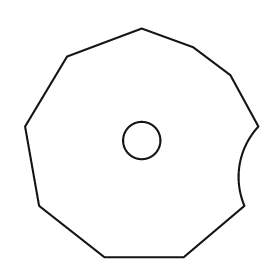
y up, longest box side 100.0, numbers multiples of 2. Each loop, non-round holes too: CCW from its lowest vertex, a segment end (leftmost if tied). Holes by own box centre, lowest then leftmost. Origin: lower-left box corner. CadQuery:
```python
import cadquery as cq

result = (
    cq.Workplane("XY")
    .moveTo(34.0, 0.0)
    .lineTo(68.0, 0.0)
    .lineTo(94.0, 22.0)
    .threePointArc((92.0, 40.0), (100.0, 56.0))
    .lineTo(88.0, 78.0)
    .lineTo(72.0, 90.0)
    .lineTo(50.0, 98.0)
    .lineTo(18.0, 86.0)
    .lineTo(0.0, 56.0)
    .lineTo(6.0, 22.0)
    .close()
    .moveTo(50.0, 50.0)
    .circle(8.0)
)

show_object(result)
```